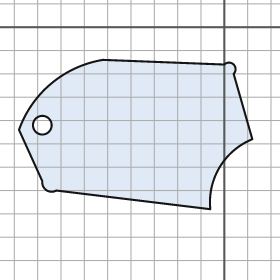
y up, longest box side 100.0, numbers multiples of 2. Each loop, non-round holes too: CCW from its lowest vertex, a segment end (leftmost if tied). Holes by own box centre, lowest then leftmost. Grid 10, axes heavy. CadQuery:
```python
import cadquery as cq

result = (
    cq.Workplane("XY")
    .moveTo(-6.0, -78.0)
    .threePointArc((-2.0, -60.0), (12.0, -48.0))
    .lineTo(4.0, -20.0)
    .threePointArc((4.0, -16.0), (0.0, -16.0))
    .lineTo(-52.0, -14.0)
    .threePointArc((-74.0, -24.0), (-88.0, -44.0))
    .lineTo(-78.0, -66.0)
    .threePointArc((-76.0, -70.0), (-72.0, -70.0))
    .close()
    .moveTo(-78.0, -42.0)
    .circle(4.0)
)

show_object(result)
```